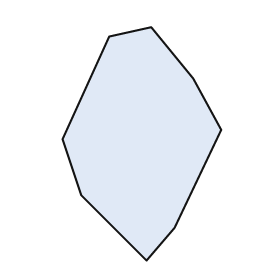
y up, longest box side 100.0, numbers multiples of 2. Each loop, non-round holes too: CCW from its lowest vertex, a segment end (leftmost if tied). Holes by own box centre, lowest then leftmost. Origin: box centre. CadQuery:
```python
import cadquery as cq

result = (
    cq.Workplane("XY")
    .moveTo(2.0, -50.0)
    .lineTo(14.0, -36.0)
    .lineTo(34.0, 6.0)
    .lineTo(22.0, 28.0)
    .lineTo(4.0, 50.0)
    .lineTo(-14.0, 46.0)
    .lineTo(-34.0, 2.0)
    .lineTo(-26.0, -22.0)
    .close()
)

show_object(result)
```